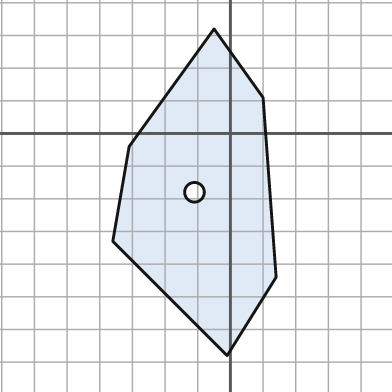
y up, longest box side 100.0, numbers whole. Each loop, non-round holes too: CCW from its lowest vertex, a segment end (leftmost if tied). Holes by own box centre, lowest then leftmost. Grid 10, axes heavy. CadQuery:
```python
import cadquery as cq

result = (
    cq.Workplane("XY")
    .moveTo(-1.0, -68.0)
    .lineTo(14.0, -44.0)
    .lineTo(10.0, 11.0)
    .lineTo(-5.0, 32.0)
    .lineTo(-31.0, -4.0)
    .lineTo(-36.0, -33.0)
    .close()
    .moveTo(-11.0, -18.0)
    .circle(3.0)
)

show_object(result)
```